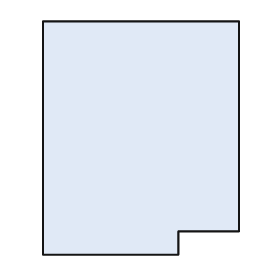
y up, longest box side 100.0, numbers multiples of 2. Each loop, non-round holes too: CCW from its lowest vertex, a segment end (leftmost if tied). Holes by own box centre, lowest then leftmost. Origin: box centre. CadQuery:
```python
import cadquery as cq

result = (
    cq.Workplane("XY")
    .moveTo(-42.0, -50.0)
    .lineTo(16.0, -50.0)
    .lineTo(16.0, -40.0)
    .lineTo(42.0, -40.0)
    .lineTo(42.0, 50.0)
    .lineTo(-42.0, 50.0)
    .close()
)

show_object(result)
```